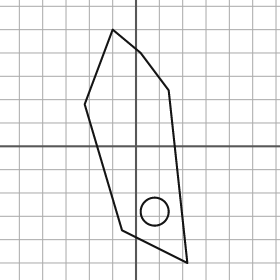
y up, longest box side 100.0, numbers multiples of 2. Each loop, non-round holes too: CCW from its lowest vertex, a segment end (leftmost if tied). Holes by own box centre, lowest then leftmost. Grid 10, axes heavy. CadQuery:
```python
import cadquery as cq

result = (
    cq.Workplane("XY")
    .moveTo(22.0, -50.0)
    .lineTo(14.0, 24.0)
    .lineTo(2.0, 40.0)
    .lineTo(-10.0, 50.0)
    .lineTo(-22.0, 18.0)
    .lineTo(-6.0, -36.0)
    .close()
    .moveTo(8.0, -28.0)
    .circle(6.0)
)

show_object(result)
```